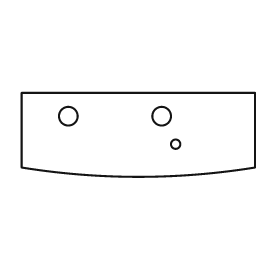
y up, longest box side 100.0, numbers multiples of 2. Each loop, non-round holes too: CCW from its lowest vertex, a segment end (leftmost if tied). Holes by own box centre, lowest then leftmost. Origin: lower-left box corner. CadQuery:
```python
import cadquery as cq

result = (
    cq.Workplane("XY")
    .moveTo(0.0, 4.0)
    .threePointArc((50.0, 0.0), (100.0, 4.0))
    .lineTo(100.0, 36.0)
    .lineTo(0.0, 36.0)
    .close()
    .moveTo(66.0, 14.0)
    .circle(2.0)
    .moveTo(20.0, 26.0)
    .circle(4.0)
    .moveTo(60.0, 26.0)
    .circle(4.0)
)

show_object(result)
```